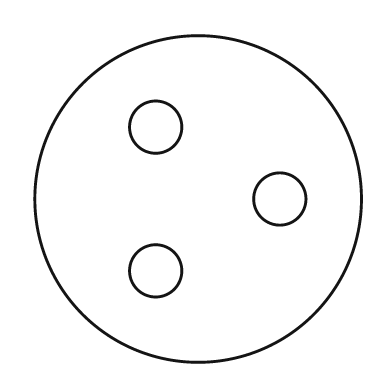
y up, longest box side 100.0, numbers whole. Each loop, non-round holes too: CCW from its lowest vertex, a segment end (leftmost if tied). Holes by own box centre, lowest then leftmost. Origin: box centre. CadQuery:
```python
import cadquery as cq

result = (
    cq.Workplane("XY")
    .moveTo(0.0, 0.0)
    .circle(50.0)
    .moveTo(-13.0, -22.0)
    .circle(8.0)
    .moveTo(25.0, 0.0)
    .circle(8.0)
    .moveTo(-13.0, 22.0)
    .circle(8.0)
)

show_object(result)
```